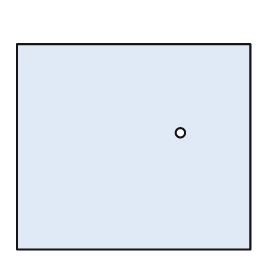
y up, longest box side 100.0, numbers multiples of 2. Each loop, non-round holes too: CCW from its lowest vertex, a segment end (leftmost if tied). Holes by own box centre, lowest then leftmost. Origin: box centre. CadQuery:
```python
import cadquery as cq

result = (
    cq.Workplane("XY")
    .moveTo(-50.0, -44.0)
    .lineTo(50.0, -44.0)
    .lineTo(50.0, 44.0)
    .lineTo(-50.0, 44.0)
    .close()
    .moveTo(20.0, 6.0)
    .circle(2.0)
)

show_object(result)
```